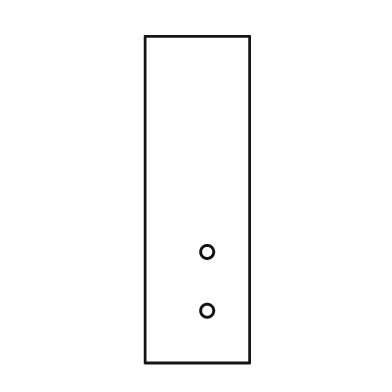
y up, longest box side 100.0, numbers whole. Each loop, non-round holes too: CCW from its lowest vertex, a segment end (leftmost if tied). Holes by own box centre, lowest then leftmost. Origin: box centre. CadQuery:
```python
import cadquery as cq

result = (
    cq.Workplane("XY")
    .moveTo(-16.0, -50.0)
    .lineTo(16.0, -50.0)
    .lineTo(16.0, 50.0)
    .lineTo(-16.0, 50.0)
    .close()
    .moveTo(3.0, -34.0)
    .circle(2.0)
    .moveTo(3.0, -16.0)
    .circle(2.0)
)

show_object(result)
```